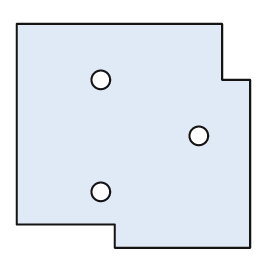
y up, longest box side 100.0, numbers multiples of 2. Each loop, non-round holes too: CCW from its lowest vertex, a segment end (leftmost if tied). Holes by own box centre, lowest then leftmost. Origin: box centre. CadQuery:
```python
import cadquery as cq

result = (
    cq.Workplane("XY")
    .moveTo(-8.0, -48.0)
    .lineTo(50.0, -48.0)
    .lineTo(50.0, 24.0)
    .lineTo(38.0, 24.0)
    .lineTo(38.0, 48.0)
    .lineTo(-50.0, 48.0)
    .lineTo(-50.0, -38.0)
    .lineTo(-8.0, -38.0)
    .close()
    .moveTo(-14.0, -24.0)
    .circle(4.0)
    .moveTo(28.0, 0.0)
    .circle(4.0)
    .moveTo(-14.0, 24.0)
    .circle(4.0)
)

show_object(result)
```